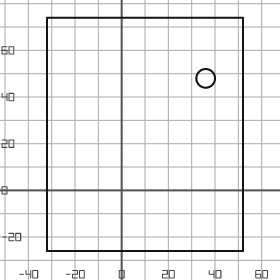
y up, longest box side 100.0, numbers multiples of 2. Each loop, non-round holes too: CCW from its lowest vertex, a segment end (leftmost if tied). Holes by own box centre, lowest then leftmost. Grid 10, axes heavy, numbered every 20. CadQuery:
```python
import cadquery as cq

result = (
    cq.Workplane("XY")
    .moveTo(-32.0, -26.0)
    .lineTo(52.0, -26.0)
    .lineTo(52.0, 74.0)
    .lineTo(-32.0, 74.0)
    .close()
    .moveTo(36.0, 48.0)
    .circle(4.0)
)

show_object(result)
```